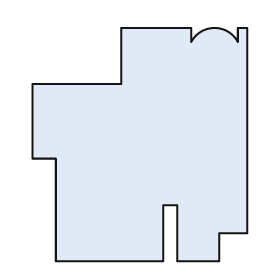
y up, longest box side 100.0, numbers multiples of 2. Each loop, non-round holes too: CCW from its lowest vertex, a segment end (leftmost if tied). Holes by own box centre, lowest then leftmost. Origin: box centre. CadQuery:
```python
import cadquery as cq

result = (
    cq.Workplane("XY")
    .moveTo(-36.0, -50.0)
    .lineTo(10.0, -50.0)
    .lineTo(10.0, -26.0)
    .lineTo(16.0, -26.0)
    .lineTo(16.0, -50.0)
    .lineTo(34.0, -50.0)
    .lineTo(34.0, -38.0)
    .lineTo(46.0, -38.0)
    .lineTo(46.0, 50.0)
    .lineTo(42.0, 50.0)
    .lineTo(42.0, 44.0)
    .threePointArc((32.0, 50.0), (22.0, 44.0))
    .lineTo(22.0, 50.0)
    .lineTo(-8.0, 50.0)
    .lineTo(-8.0, 26.0)
    .lineTo(-46.0, 26.0)
    .lineTo(-46.0, -6.0)
    .lineTo(-36.0, -6.0)
    .close()
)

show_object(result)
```